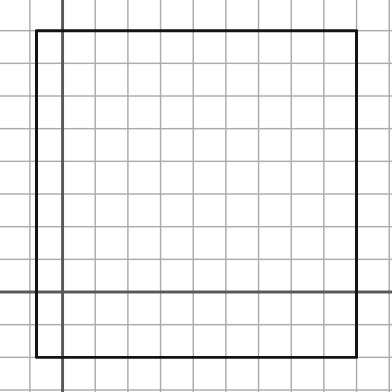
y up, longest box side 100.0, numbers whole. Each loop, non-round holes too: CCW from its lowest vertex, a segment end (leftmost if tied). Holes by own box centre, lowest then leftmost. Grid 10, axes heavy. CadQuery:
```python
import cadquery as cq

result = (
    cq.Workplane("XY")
    .moveTo(-8.0, -20.0)
    .lineTo(90.0, -20.0)
    .lineTo(90.0, 80.0)
    .lineTo(-8.0, 80.0)
    .close()
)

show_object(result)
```